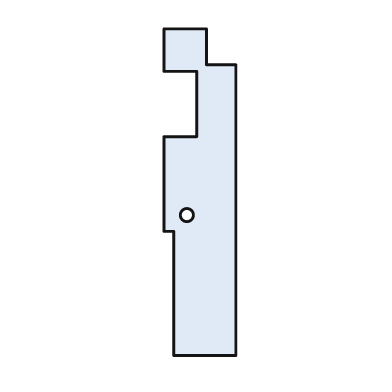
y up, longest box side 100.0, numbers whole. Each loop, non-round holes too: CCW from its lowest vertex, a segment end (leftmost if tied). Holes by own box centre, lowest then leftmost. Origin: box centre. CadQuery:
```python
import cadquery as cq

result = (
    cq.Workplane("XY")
    .moveTo(-8.0, -50.0)
    .lineTo(11.0, -50.0)
    .lineTo(11.0, 39.0)
    .lineTo(2.0, 39.0)
    .lineTo(2.0, 50.0)
    .lineTo(-11.0, 50.0)
    .lineTo(-11.0, 37.0)
    .lineTo(-1.0, 37.0)
    .lineTo(-1.0, 17.0)
    .lineTo(-11.0, 17.0)
    .lineTo(-11.0, -12.0)
    .lineTo(-8.0, -12.0)
    .close()
    .moveTo(-4.0, -7.0)
    .circle(2.0)
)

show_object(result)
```